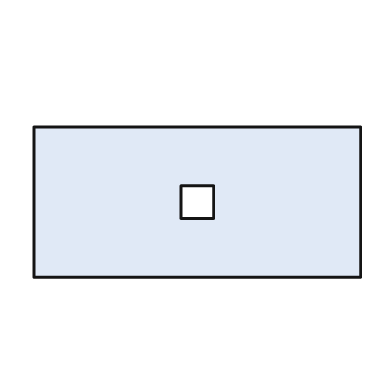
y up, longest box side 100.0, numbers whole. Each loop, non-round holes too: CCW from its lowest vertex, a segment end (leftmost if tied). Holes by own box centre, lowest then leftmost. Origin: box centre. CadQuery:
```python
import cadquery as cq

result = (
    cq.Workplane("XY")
    .moveTo(-50.0, -23.0)
    .lineTo(50.0, -23.0)
    .lineTo(50.0, 23.0)
    .lineTo(-50.0, 23.0)
    .close()
    .moveTo(-5.0, -5.0)
    .lineTo(5.0, -5.0)
    .lineTo(5.0, 5.0)
    .lineTo(-5.0, 5.0)
    .close()
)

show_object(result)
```